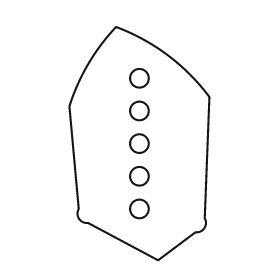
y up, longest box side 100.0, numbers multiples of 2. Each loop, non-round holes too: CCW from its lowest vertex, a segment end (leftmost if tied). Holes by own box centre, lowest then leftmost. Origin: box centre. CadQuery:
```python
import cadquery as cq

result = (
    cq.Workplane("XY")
    .moveTo(8.0, -50.0)
    .lineTo(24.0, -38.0)
    .threePointArc((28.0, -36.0), (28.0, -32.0))
    .lineTo(30.0, 20.0)
    .threePointArc((12.0, 38.0), (-10.0, 50.0))
    .threePointArc((-22.0, 34.0), (-30.0, 16.0))
    .lineTo(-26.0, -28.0)
    .threePointArc((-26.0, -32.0), (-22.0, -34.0))
    .close()
    .moveTo(0.0, -28.0)
    .circle(4.0)
    .moveTo(0.0, -14.0)
    .circle(4.0)
    .moveTo(0.0, 0.0)
    .circle(4.0)
    .moveTo(0.0, 14.0)
    .circle(4.0)
    .moveTo(0.0, 28.0)
    .circle(4.0)
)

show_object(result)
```